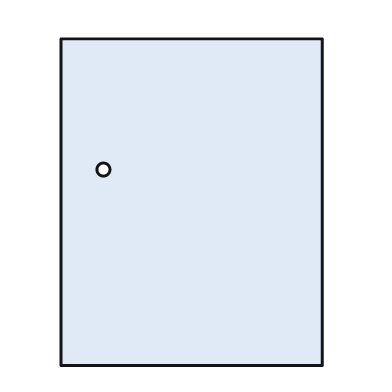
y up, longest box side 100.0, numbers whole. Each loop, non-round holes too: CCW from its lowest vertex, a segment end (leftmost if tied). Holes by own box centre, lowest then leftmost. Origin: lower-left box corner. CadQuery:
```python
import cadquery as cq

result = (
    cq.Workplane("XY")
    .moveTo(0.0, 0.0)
    .lineTo(80.0, 0.0)
    .lineTo(80.0, 100.0)
    .lineTo(0.0, 100.0)
    .close()
    .moveTo(13.0, 60.0)
    .circle(2.0)
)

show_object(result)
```